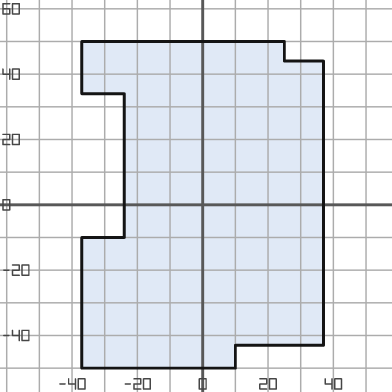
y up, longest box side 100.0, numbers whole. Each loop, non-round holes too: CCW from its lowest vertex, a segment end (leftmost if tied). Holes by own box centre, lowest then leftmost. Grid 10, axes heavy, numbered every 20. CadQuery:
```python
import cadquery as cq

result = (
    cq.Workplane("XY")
    .moveTo(-37.0, -50.0)
    .lineTo(10.0, -50.0)
    .lineTo(10.0, -43.0)
    .lineTo(37.0, -43.0)
    .lineTo(37.0, 44.0)
    .lineTo(25.0, 44.0)
    .lineTo(25.0, 50.0)
    .lineTo(-37.0, 50.0)
    .lineTo(-37.0, 34.0)
    .lineTo(-24.0, 34.0)
    .lineTo(-24.0, -10.0)
    .lineTo(-37.0, -10.0)
    .close()
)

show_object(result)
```